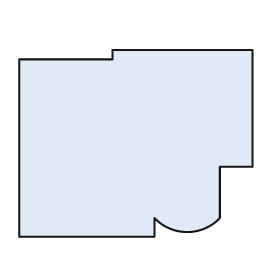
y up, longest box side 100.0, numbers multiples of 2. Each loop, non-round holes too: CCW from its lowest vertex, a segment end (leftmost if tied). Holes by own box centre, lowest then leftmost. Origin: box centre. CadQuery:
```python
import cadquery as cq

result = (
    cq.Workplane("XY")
    .moveTo(-50.0, -40.0)
    .lineTo(8.0, -40.0)
    .lineTo(8.0, -32.0)
    .threePointArc((22.0, -38.0), (36.0, -32.0))
    .lineTo(36.0, -10.0)
    .lineTo(50.0, -10.0)
    .lineTo(50.0, 40.0)
    .lineTo(-10.0, 40.0)
    .lineTo(-10.0, 36.0)
    .lineTo(-50.0, 36.0)
    .close()
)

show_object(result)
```